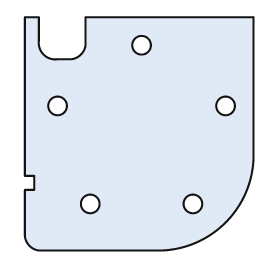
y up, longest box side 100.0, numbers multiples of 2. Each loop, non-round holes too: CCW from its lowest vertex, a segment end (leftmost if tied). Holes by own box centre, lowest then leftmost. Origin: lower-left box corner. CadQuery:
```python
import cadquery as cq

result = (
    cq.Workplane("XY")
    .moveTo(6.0, 0.0)
    .lineTo(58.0, 0.0)
    .threePointArc((86.0, 12.0), (98.0, 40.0))
    .lineTo(98.0, 100.0)
    .lineTo(26.0, 100.0)
    .lineTo(26.0, 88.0)
    .threePointArc((24.0, 84.0), (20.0, 82.0))
    .lineTo(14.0, 82.0)
    .threePointArc((8.0, 84.0), (6.0, 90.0))
    .lineTo(6.0, 100.0)
    .lineTo(0.0, 100.0)
    .lineTo(0.0, 32.0)
    .lineTo(4.0, 32.0)
    .lineTo(4.0, 26.0)
    .lineTo(0.0, 26.0)
    .lineTo(0.0, 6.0)
    .threePointArc((2.0, 2.0), (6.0, 0.0))
    .close()
    .moveTo(28.0, 20.0)
    .circle(4.0)
    .moveTo(72.0, 20.0)
    .circle(4.0)
    .moveTo(14.0, 62.0)
    .circle(4.0)
    .moveTo(86.0, 62.0)
    .circle(4.0)
    .moveTo(50.0, 88.0)
    .circle(4.0)
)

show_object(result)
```